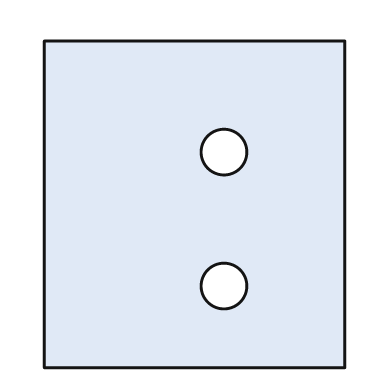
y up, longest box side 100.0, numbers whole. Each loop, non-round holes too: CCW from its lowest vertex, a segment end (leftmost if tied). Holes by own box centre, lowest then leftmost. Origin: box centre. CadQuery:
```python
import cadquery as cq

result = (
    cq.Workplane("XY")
    .moveTo(-46.0, -50.0)
    .lineTo(46.0, -50.0)
    .lineTo(46.0, 50.0)
    .lineTo(-46.0, 50.0)
    .close()
    .moveTo(9.0, -25.0)
    .circle(7.0)
    .moveTo(9.0, 16.0)
    .circle(7.0)
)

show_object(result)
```